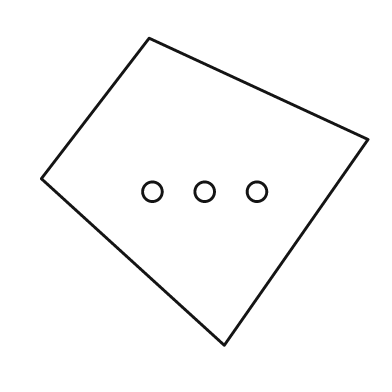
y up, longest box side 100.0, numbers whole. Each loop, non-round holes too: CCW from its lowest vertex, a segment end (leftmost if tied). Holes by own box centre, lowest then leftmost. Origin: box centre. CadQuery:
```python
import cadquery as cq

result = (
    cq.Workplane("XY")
    .moveTo(6.0, -47.0)
    .lineTo(50.0, 16.0)
    .lineTo(-17.0, 47.0)
    .lineTo(-50.0, 4.0)
    .close()
    .moveTo(-16.0, 0.0)
    .circle(3.0)
    .moveTo(0.0, 0.0)
    .circle(3.0)
    .moveTo(16.0, 0.0)
    .circle(3.0)
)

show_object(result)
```